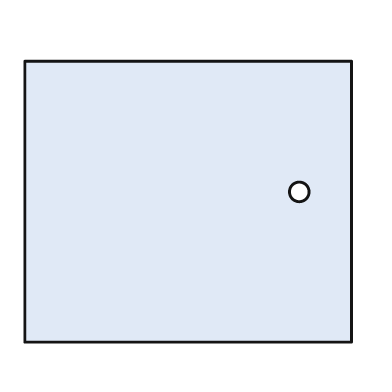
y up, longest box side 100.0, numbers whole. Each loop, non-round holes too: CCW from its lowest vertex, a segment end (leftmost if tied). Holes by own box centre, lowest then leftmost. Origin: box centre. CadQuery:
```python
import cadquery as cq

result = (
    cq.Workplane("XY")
    .moveTo(-50.0, -43.0)
    .lineTo(50.0, -43.0)
    .lineTo(50.0, 43.0)
    .lineTo(-50.0, 43.0)
    .close()
    .moveTo(34.0, 3.0)
    .circle(3.0)
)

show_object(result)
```